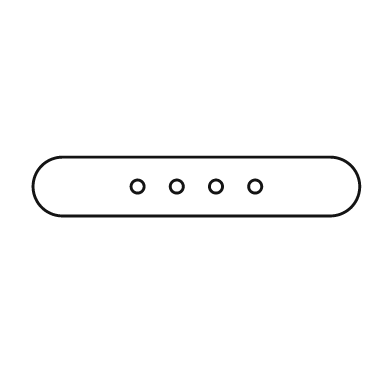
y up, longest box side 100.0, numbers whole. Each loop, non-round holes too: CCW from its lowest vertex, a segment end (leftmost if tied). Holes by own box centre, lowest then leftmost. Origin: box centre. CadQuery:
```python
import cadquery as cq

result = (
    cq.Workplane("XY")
    .moveTo(-41.0, -9.0)
    .lineTo(41.0, -9.0)
    .threePointArc((50.0, 0.0), (41.0, 9.0))
    .lineTo(-41.0, 9.0)
    .threePointArc((-50.0, 0.0), (-41.0, -9.0))
    .close()
    .moveTo(-18.0, 0.0)
    .circle(2.0)
    .moveTo(-6.0, 0.0)
    .circle(2.0)
    .moveTo(6.0, 0.0)
    .circle(2.0)
    .moveTo(18.0, 0.0)
    .circle(2.0)
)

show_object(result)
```